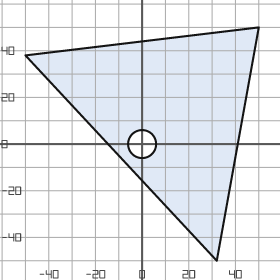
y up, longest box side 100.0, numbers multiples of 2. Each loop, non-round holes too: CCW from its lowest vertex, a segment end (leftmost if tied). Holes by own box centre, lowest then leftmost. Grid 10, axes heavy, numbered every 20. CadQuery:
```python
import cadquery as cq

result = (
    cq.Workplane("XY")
    .moveTo(32.0, -50.0)
    .lineTo(50.0, 50.0)
    .lineTo(-50.0, 38.0)
    .close()
    .moveTo(0.0, 0.0)
    .circle(6.0)
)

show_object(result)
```